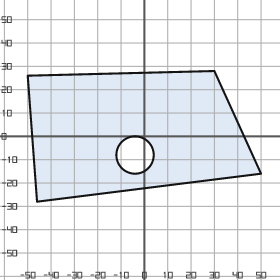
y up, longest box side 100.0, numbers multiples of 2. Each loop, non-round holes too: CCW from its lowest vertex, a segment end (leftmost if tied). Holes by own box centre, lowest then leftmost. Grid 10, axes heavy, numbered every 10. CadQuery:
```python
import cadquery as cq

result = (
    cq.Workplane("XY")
    .moveTo(-46.0, -28.0)
    .lineTo(50.0, -16.0)
    .lineTo(30.0, 28.0)
    .lineTo(-50.0, 26.0)
    .close()
    .moveTo(-4.0, -8.0)
    .circle(8.0)
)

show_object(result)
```